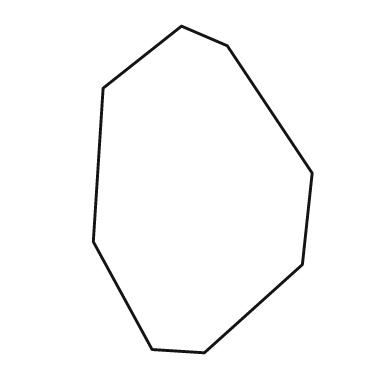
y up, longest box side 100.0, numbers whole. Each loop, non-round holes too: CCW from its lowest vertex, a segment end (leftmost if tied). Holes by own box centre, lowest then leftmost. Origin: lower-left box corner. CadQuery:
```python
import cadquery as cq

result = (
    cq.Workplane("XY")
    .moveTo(34.0, 0.0)
    .lineTo(64.0, 27.0)
    .lineTo(67.0, 55.0)
    .lineTo(41.0, 94.0)
    .lineTo(27.0, 100.0)
    .lineTo(3.0, 81.0)
    .lineTo(0.0, 34.0)
    .lineTo(18.0, 1.0)
    .close()
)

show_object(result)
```